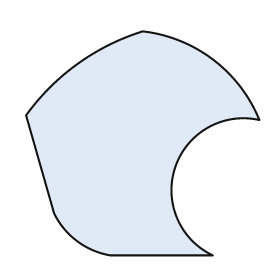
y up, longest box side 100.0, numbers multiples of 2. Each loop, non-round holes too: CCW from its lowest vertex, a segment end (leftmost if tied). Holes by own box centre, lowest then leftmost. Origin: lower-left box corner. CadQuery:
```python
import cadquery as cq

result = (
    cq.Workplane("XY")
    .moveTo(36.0, 0.0)
    .lineTo(80.0, 0.0)
    .threePointArc((64.0, 38.0), (100.0, 58.0))
    .threePointArc((80.0, 84.0), (50.0, 96.0))
    .threePointArc((22.0, 82.0), (0.0, 60.0))
    .lineTo(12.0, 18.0)
    .threePointArc((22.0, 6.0), (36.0, 0.0))
    .close()
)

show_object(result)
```